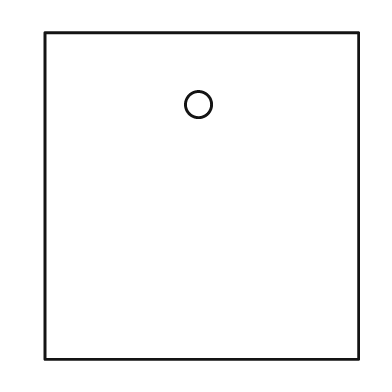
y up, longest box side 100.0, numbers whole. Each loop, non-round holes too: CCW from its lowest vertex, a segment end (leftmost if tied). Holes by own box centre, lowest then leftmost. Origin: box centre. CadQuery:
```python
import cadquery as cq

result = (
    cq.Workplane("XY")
    .moveTo(-48.0, -50.0)
    .lineTo(48.0, -50.0)
    .lineTo(48.0, 50.0)
    .lineTo(-48.0, 50.0)
    .close()
    .moveTo(-1.0, 28.0)
    .circle(4.0)
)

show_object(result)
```